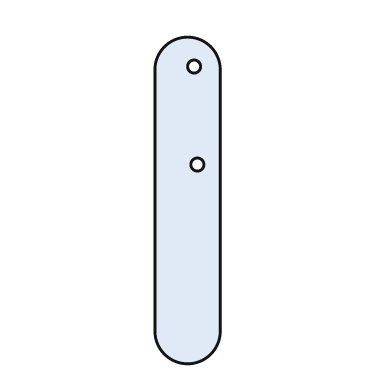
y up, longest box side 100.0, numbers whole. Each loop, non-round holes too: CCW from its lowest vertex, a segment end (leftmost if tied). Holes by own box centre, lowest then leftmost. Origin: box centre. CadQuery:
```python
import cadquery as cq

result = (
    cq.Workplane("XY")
    .moveTo(-10.0, -40.0)
    .threePointArc((0.0, -50.0), (10.0, -40.0))
    .lineTo(10.0, 40.0)
    .threePointArc((0.0, 50.0), (-10.0, 40.0))
    .close()
    .moveTo(3.0, 11.0)
    .circle(2.0)
    .moveTo(2.0, 41.0)
    .circle(2.0)
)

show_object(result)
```